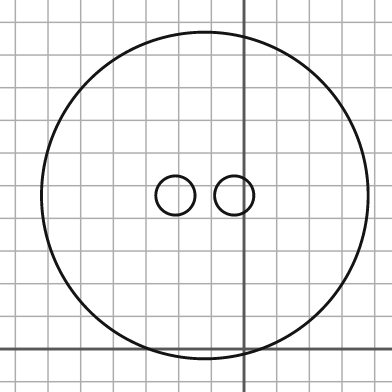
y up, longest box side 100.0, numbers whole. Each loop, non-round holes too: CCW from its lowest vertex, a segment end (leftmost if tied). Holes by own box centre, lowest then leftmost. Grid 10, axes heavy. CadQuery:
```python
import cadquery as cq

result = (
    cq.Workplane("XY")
    .moveTo(-12.0, 47.0)
    .circle(50.0)
    .moveTo(-21.0, 47.0)
    .circle(6.0)
    .moveTo(-3.0, 47.0)
    .circle(6.0)
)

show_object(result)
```